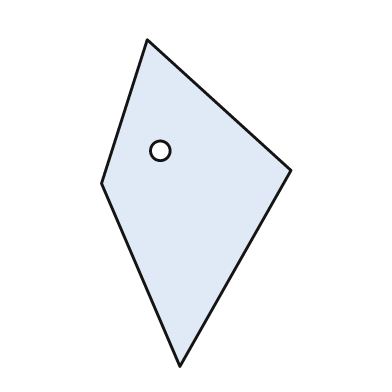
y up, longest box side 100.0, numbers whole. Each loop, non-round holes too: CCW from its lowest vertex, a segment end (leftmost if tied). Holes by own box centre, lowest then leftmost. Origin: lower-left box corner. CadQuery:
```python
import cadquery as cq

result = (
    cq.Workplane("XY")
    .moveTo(24.0, 0.0)
    .lineTo(58.0, 60.0)
    .lineTo(14.0, 100.0)
    .lineTo(0.0, 56.0)
    .close()
    .moveTo(18.0, 66.0)
    .circle(3.0)
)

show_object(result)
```